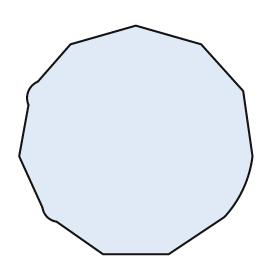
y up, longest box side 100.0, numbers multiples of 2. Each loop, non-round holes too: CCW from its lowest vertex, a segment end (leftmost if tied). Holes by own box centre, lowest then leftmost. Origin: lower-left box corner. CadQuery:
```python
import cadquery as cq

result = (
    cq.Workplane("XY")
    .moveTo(36.0, 0.0)
    .lineTo(64.0, 0.0)
    .lineTo(88.0, 16.0)
    .threePointArc((96.0, 28.0), (100.0, 42.0))
    .lineTo(96.0, 70.0)
    .lineTo(78.0, 90.0)
    .lineTo(50.0, 98.0)
    .lineTo(22.0, 90.0)
    .lineTo(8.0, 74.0)
    .threePointArc((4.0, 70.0), (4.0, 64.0))
    .lineTo(0.0, 42.0)
    .lineTo(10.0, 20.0)
    .threePointArc((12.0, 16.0), (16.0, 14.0))
    .close()
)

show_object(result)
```